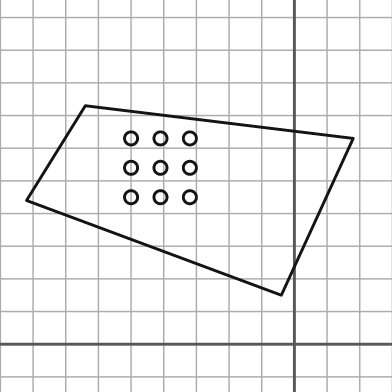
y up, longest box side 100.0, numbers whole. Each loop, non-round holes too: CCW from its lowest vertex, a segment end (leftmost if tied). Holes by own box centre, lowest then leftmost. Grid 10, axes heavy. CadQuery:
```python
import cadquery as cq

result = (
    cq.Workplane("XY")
    .moveTo(-4.0, 15.0)
    .lineTo(18.0, 63.0)
    .lineTo(-64.0, 73.0)
    .lineTo(-82.0, 44.0)
    .close()
    .moveTo(-50.0, 45.0)
    .circle(2.0)
    .moveTo(-41.0, 45.0)
    .circle(2.0)
    .moveTo(-32.0, 45.0)
    .circle(2.0)
    .moveTo(-50.0, 54.0)
    .circle(2.0)
    .moveTo(-41.0, 54.0)
    .circle(2.0)
    .moveTo(-32.0, 54.0)
    .circle(2.0)
    .moveTo(-50.0, 63.0)
    .circle(2.0)
    .moveTo(-41.0, 63.0)
    .circle(2.0)
    .moveTo(-32.0, 63.0)
    .circle(2.0)
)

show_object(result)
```